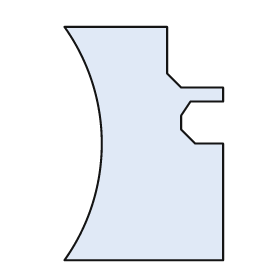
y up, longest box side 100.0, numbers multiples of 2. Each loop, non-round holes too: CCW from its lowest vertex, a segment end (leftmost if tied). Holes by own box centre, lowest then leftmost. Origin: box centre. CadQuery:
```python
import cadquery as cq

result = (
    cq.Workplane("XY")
    .moveTo(-34.0, -50.0)
    .lineTo(34.0, -50.0)
    .lineTo(34.0, 0.0)
    .lineTo(22.0, 0.0)
    .lineTo(16.0, 6.0)
    .lineTo(16.0, 12.0)
    .lineTo(20.0, 18.0)
    .lineTo(34.0, 18.0)
    .lineTo(34.0, 24.0)
    .lineTo(16.0, 24.0)
    .lineTo(10.0, 30.0)
    .lineTo(10.0, 50.0)
    .lineTo(-34.0, 50.0)
    .threePointArc((-18.0, 0.0), (-34.0, -50.0))
    .close()
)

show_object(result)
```